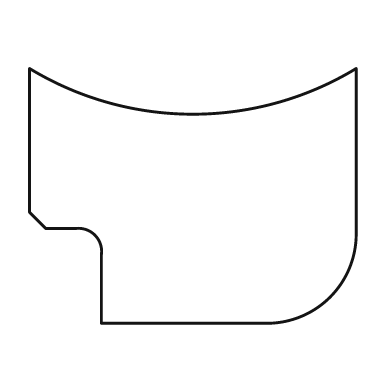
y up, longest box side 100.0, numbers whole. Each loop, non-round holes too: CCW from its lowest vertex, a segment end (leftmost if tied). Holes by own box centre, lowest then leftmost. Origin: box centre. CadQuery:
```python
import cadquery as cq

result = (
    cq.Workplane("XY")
    .moveTo(-28.0, -39.0)
    .lineTo(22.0, -39.0)
    .threePointArc((42.0, -31.0), (50.0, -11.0))
    .lineTo(50.0, 39.0)
    .threePointArc((0.0, 25.0), (-50.0, 39.0))
    .lineTo(-50.0, -5.0)
    .lineTo(-45.0, -10.0)
    .lineTo(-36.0, -10.0)
    .threePointArc((-30.0, -12.0), (-28.0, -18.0))
    .close()
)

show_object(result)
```